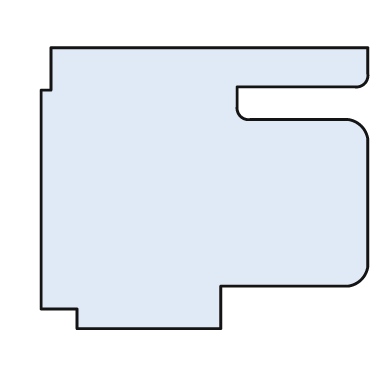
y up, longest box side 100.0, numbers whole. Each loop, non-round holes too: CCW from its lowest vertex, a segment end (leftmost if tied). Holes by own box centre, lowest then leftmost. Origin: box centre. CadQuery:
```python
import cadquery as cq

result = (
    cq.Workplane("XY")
    .moveTo(-39.0, -43.0)
    .lineTo(5.0, -43.0)
    .lineTo(5.0, -30.0)
    .lineTo(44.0, -30.0)
    .threePointArc((48.0, -28.0), (50.0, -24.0))
    .lineTo(50.0, 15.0)
    .threePointArc((48.0, 19.0), (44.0, 21.0))
    .lineTo(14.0, 21.0)
    .threePointArc((11.0, 22.0), (10.0, 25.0))
    .lineTo(10.0, 31.0)
    .lineTo(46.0, 31.0)
    .threePointArc((49.0, 32.0), (50.0, 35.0))
    .lineTo(50.0, 43.0)
    .lineTo(-47.0, 43.0)
    .lineTo(-47.0, 30.0)
    .lineTo(-50.0, 30.0)
    .lineTo(-50.0, -37.0)
    .lineTo(-39.0, -37.0)
    .close()
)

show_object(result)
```